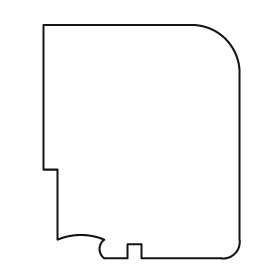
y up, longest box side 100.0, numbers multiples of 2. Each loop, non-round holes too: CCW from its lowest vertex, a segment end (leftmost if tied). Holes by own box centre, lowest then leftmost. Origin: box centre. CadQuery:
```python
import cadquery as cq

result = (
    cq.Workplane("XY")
    .moveTo(-16.0, -50.0)
    .lineTo(-6.0, -50.0)
    .lineTo(-6.0, -44.0)
    .lineTo(0.0, -44.0)
    .lineTo(0.0, -50.0)
    .lineTo(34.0, -50.0)
    .threePointArc((40.0, -48.0), (42.0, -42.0))
    .lineTo(42.0, 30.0)
    .threePointArc((36.0, 44.0), (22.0, 50.0))
    .lineTo(-42.0, 50.0)
    .lineTo(-42.0, -12.0)
    .lineTo(-36.0, -12.0)
    .lineTo(-36.0, -42.0)
    .threePointArc((-26.0, -40.0), (-16.0, -42.0))
    .threePointArc((-18.0, -46.0), (-16.0, -50.0))
    .close()
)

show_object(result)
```